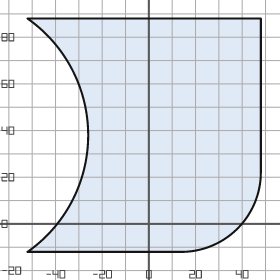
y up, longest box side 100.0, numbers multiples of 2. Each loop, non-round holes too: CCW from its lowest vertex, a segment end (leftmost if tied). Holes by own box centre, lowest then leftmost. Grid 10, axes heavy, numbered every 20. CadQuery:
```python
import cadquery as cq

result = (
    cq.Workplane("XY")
    .moveTo(-52.0, -12.0)
    .lineTo(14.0, -12.0)
    .threePointArc((38.0, -2.0), (48.0, 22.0))
    .lineTo(48.0, 88.0)
    .lineTo(-52.0, 88.0)
    .threePointArc((-26.0, 38.0), (-52.0, -12.0))
    .close()
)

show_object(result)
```